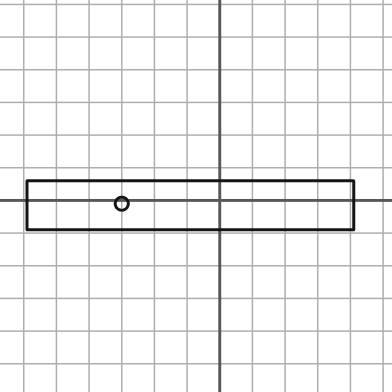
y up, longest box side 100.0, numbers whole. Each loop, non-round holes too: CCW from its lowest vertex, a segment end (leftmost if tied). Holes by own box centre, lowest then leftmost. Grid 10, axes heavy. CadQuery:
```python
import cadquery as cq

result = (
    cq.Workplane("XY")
    .moveTo(-59.0, -9.0)
    .lineTo(41.0, -9.0)
    .lineTo(41.0, 6.0)
    .lineTo(-59.0, 6.0)
    .close()
    .moveTo(-30.0, -1.0)
    .circle(2.0)
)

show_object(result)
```